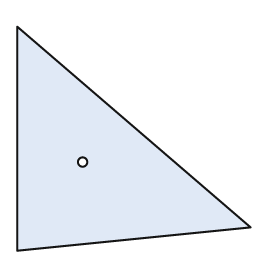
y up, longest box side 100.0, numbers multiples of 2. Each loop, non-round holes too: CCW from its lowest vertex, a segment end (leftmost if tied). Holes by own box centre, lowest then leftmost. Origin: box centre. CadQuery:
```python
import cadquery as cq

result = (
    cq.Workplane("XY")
    .moveTo(-50.0, -48.0)
    .lineTo(50.0, -38.0)
    .lineTo(-50.0, 48.0)
    .close()
    .moveTo(-22.0, -10.0)
    .circle(2.0)
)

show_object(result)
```